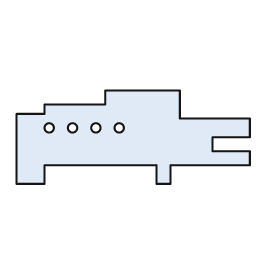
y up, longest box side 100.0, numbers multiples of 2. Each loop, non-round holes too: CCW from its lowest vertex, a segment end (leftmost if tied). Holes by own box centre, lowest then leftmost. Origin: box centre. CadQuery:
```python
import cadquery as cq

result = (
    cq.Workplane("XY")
    .moveTo(-50.0, -20.0)
    .lineTo(-38.0, -20.0)
    .lineTo(-38.0, -12.0)
    .lineTo(10.0, -12.0)
    .lineTo(10.0, -20.0)
    .lineTo(16.0, -20.0)
    .lineTo(16.0, -12.0)
    .lineTo(50.0, -12.0)
    .lineTo(50.0, -6.0)
    .lineTo(34.0, -6.0)
    .lineTo(34.0, 0.0)
    .lineTo(50.0, 0.0)
    .lineTo(50.0, 8.0)
    .lineTo(20.0, 8.0)
    .lineTo(20.0, 20.0)
    .lineTo(-12.0, 20.0)
    .lineTo(-12.0, 14.0)
    .lineTo(-38.0, 14.0)
    .lineTo(-38.0, 10.0)
    .lineTo(-50.0, 10.0)
    .close()
    .moveTo(-36.0, 4.0)
    .circle(2.0)
    .moveTo(-26.0, 4.0)
    .circle(2.0)
    .moveTo(-16.0, 4.0)
    .circle(2.0)
    .moveTo(-6.0, 4.0)
    .circle(2.0)
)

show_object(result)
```